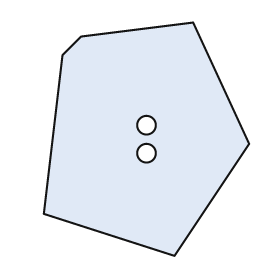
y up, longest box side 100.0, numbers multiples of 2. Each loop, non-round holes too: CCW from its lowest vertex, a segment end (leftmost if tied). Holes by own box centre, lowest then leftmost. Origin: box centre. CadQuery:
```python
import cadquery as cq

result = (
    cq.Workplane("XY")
    .moveTo(12.0, -50.0)
    .lineTo(44.0, -2.0)
    .lineTo(20.0, 50.0)
    .lineTo(-28.0, 44.0)
    .lineTo(-36.0, 36.0)
    .lineTo(-44.0, -32.0)
    .close()
    .moveTo(0.0, -6.0)
    .circle(4.0)
    .moveTo(0.0, 6.0)
    .circle(4.0)
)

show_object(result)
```